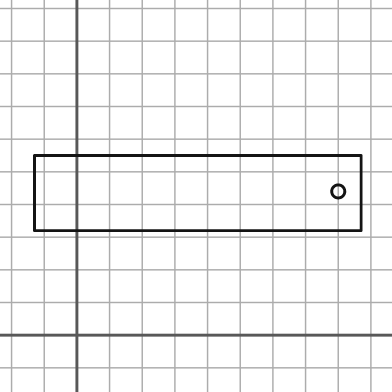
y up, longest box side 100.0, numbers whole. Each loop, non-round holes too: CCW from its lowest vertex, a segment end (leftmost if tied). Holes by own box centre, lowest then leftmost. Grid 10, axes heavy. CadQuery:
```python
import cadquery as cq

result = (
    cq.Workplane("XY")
    .moveTo(-13.0, 32.0)
    .lineTo(87.0, 32.0)
    .lineTo(87.0, 55.0)
    .lineTo(-13.0, 55.0)
    .close()
    .moveTo(80.0, 44.0)
    .circle(2.0)
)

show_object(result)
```